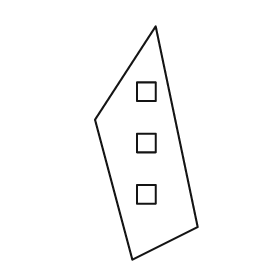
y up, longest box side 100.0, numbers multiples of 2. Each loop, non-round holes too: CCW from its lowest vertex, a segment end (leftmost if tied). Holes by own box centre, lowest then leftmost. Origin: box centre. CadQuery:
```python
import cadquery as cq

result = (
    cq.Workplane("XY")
    .moveTo(-6.0, -50.0)
    .lineTo(22.0, -36.0)
    .lineTo(4.0, 50.0)
    .lineTo(-22.0, 10.0)
    .close()
    .moveTo(-4.0, -26.0)
    .lineTo(4.0, -26.0)
    .lineTo(4.0, -18.0)
    .lineTo(-4.0, -18.0)
    .close()
    .moveTo(-4.0, -4.0)
    .lineTo(4.0, -4.0)
    .lineTo(4.0, 4.0)
    .lineTo(-4.0, 4.0)
    .close()
    .moveTo(-4.0, 18.0)
    .lineTo(4.0, 18.0)
    .lineTo(4.0, 26.0)
    .lineTo(-4.0, 26.0)
    .close()
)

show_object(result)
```